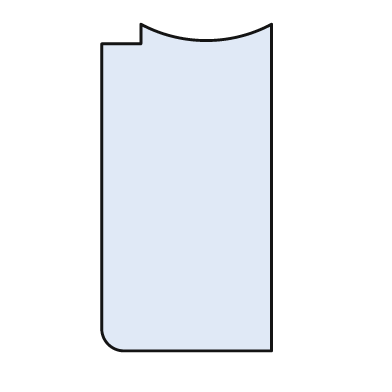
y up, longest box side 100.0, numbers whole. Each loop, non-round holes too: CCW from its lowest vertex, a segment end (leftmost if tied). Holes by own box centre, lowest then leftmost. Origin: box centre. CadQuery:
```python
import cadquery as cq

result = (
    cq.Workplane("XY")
    .moveTo(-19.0, -50.0)
    .lineTo(26.0, -50.0)
    .lineTo(26.0, 50.0)
    .threePointArc((6.0, 45.0), (-14.0, 50.0))
    .lineTo(-14.0, 44.0)
    .lineTo(-26.0, 44.0)
    .lineTo(-26.0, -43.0)
    .threePointArc((-24.0, -48.0), (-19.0, -50.0))
    .close()
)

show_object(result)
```